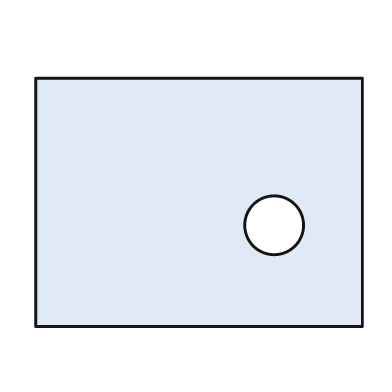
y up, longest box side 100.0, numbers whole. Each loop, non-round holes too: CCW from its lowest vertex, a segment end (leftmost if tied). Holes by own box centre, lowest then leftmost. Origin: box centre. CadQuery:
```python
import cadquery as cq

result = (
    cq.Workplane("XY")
    .moveTo(-50.0, -38.0)
    .lineTo(50.0, -38.0)
    .lineTo(50.0, 38.0)
    .lineTo(-50.0, 38.0)
    .close()
    .moveTo(23.0, -7.0)
    .circle(9.0)
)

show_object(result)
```